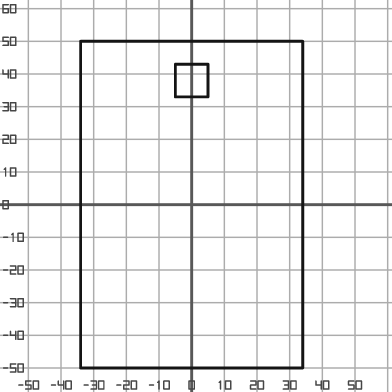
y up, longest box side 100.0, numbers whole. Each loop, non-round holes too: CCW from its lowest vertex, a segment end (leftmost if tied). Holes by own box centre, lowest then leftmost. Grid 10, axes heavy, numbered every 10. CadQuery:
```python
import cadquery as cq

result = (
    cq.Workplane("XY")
    .moveTo(-34.0, -50.0)
    .lineTo(34.0, -50.0)
    .lineTo(34.0, 50.0)
    .lineTo(-34.0, 50.0)
    .close()
    .moveTo(-5.0, 33.0)
    .lineTo(5.0, 33.0)
    .lineTo(5.0, 43.0)
    .lineTo(-5.0, 43.0)
    .close()
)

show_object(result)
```